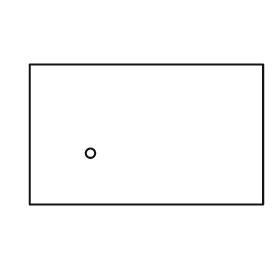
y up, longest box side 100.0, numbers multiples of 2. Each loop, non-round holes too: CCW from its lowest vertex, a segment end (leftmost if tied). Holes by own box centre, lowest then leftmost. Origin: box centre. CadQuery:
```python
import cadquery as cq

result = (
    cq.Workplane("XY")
    .moveTo(-50.0, -30.0)
    .lineTo(50.0, -30.0)
    .lineTo(50.0, 30.0)
    .lineTo(-50.0, 30.0)
    .close()
    .moveTo(-24.0, -8.0)
    .circle(2.0)
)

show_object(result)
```